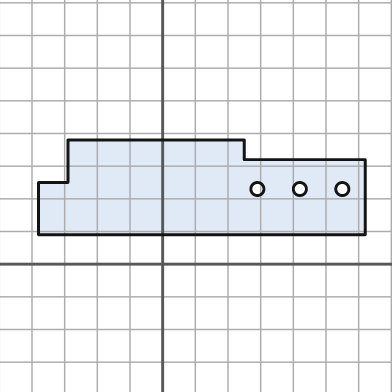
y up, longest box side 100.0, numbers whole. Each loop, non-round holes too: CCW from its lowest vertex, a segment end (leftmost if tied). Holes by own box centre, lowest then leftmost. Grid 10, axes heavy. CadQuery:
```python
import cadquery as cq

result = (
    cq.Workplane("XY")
    .moveTo(-38.0, 9.0)
    .lineTo(62.0, 9.0)
    .lineTo(62.0, 32.0)
    .lineTo(25.0, 32.0)
    .lineTo(25.0, 38.0)
    .lineTo(-29.0, 38.0)
    .lineTo(-29.0, 25.0)
    .lineTo(-38.0, 25.0)
    .close()
    .moveTo(29.0, 23.0)
    .circle(2.0)
    .moveTo(42.0, 23.0)
    .circle(2.0)
    .moveTo(55.0, 23.0)
    .circle(2.0)
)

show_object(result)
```